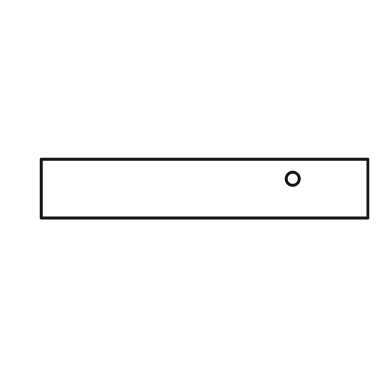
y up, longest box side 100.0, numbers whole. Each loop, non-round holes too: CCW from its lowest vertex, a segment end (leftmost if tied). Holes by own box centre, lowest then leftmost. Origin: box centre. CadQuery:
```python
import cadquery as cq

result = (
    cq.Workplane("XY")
    .moveTo(-50.0, -9.0)
    .lineTo(50.0, -9.0)
    .lineTo(50.0, 9.0)
    .lineTo(-50.0, 9.0)
    .close()
    .moveTo(27.0, 3.0)
    .circle(2.0)
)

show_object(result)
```